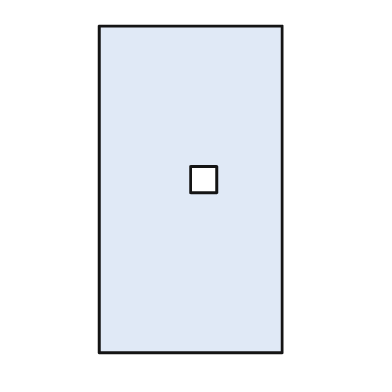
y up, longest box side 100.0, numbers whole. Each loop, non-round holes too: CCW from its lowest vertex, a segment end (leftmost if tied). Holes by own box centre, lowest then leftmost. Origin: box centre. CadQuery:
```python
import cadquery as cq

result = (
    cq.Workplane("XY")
    .moveTo(-28.0, -50.0)
    .lineTo(28.0, -50.0)
    .lineTo(28.0, 50.0)
    .lineTo(-28.0, 50.0)
    .close()
    .moveTo(0.0, -1.0)
    .lineTo(8.0, -1.0)
    .lineTo(8.0, 7.0)
    .lineTo(0.0, 7.0)
    .close()
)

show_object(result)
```